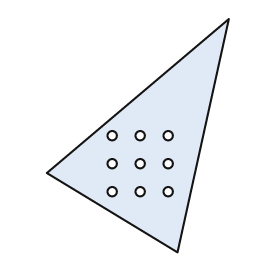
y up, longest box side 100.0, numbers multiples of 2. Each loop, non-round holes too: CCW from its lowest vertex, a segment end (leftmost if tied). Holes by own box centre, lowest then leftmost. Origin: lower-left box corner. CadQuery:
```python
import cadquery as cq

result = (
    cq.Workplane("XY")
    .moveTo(56.0, 0.0)
    .lineTo(78.0, 100.0)
    .lineTo(0.0, 34.0)
    .close()
    .moveTo(28.0, 26.0)
    .circle(2.0)
    .moveTo(40.0, 26.0)
    .circle(2.0)
    .moveTo(52.0, 26.0)
    .circle(2.0)
    .moveTo(28.0, 38.0)
    .circle(2.0)
    .moveTo(40.0, 38.0)
    .circle(2.0)
    .moveTo(52.0, 38.0)
    .circle(2.0)
    .moveTo(28.0, 50.0)
    .circle(2.0)
    .moveTo(40.0, 50.0)
    .circle(2.0)
    .moveTo(52.0, 50.0)
    .circle(2.0)
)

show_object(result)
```